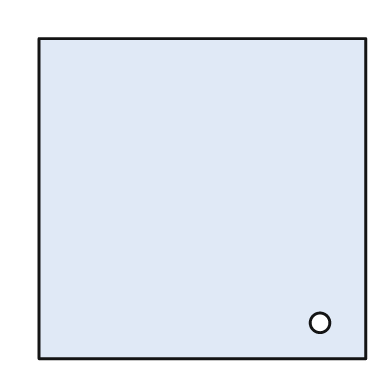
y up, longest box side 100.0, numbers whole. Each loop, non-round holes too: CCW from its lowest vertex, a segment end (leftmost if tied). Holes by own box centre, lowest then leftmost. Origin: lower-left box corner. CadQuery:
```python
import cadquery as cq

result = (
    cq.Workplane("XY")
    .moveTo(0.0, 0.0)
    .lineTo(100.0, 0.0)
    .lineTo(100.0, 98.0)
    .lineTo(0.0, 98.0)
    .close()
    .moveTo(86.0, 11.0)
    .circle(3.0)
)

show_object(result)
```